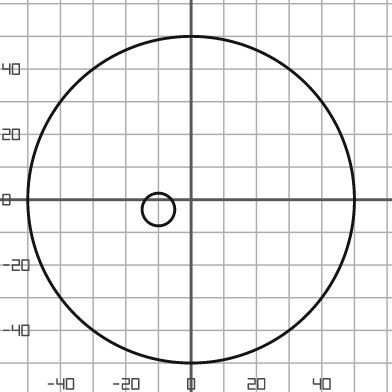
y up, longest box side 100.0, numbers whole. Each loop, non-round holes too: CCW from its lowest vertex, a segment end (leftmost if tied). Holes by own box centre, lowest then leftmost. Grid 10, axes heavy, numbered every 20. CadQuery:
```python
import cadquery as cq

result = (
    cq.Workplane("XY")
    .moveTo(0.0, 0.0)
    .circle(50.0)
    .moveTo(-10.0, -3.0)
    .circle(5.0)
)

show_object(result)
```